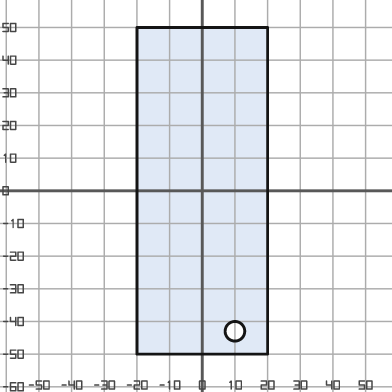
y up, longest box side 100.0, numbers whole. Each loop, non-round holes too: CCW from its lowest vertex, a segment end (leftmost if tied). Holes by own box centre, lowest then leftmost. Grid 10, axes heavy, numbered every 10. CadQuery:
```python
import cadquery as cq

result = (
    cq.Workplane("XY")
    .moveTo(-20.0, -50.0)
    .lineTo(20.0, -50.0)
    .lineTo(20.0, 50.0)
    .lineTo(-20.0, 50.0)
    .close()
    .moveTo(10.0, -43.0)
    .circle(3.0)
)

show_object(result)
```